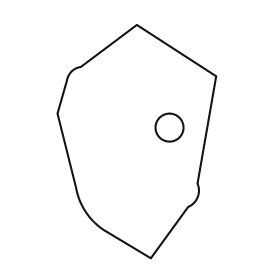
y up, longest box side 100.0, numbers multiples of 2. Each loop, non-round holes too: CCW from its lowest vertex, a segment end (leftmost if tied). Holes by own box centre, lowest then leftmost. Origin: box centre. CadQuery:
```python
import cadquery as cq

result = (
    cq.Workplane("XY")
    .moveTo(6.0, -50.0)
    .lineTo(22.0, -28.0)
    .threePointArc((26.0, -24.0), (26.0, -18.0))
    .lineTo(34.0, 28.0)
    .lineTo(0.0, 50.0)
    .lineTo(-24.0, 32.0)
    .threePointArc((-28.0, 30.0), (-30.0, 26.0))
    .lineTo(-34.0, 12.0)
    .lineTo(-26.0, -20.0)
    .threePointArc((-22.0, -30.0), (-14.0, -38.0))
    .close()
    .moveTo(14.0, 6.0)
    .circle(6.0)
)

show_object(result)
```